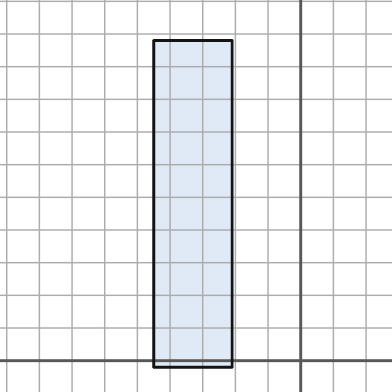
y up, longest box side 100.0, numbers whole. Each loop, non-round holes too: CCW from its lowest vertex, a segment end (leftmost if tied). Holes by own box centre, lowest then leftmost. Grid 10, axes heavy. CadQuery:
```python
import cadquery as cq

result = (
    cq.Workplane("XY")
    .moveTo(-45.0, -2.0)
    .lineTo(-21.0, -2.0)
    .lineTo(-21.0, 98.0)
    .lineTo(-45.0, 98.0)
    .close()
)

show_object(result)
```